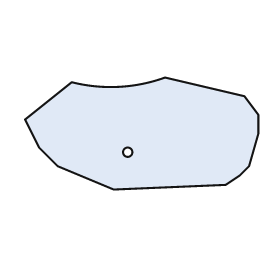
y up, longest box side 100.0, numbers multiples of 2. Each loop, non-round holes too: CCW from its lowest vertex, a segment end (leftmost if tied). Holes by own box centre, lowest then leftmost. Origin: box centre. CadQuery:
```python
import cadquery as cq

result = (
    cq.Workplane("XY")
    .moveTo(-12.0, -24.0)
    .lineTo(36.0, -22.0)
    .lineTo(42.0, -18.0)
    .lineTo(46.0, -14.0)
    .lineTo(50.0, 0.0)
    .lineTo(50.0, 8.0)
    .lineTo(44.0, 16.0)
    .lineTo(10.0, 24.0)
    .threePointArc((-10.0, 20.0), (-30.0, 22.0))
    .lineTo(-50.0, 6.0)
    .lineTo(-44.0, -6.0)
    .lineTo(-36.0, -14.0)
    .close()
    .moveTo(-6.0, -8.0)
    .circle(2.0)
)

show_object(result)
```